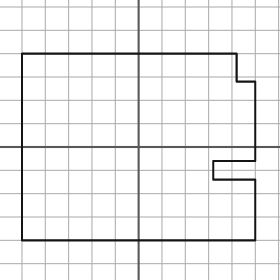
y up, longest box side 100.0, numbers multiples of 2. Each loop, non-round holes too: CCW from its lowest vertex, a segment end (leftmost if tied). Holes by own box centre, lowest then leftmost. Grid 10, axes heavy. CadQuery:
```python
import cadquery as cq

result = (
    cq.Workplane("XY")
    .moveTo(-50.0, -40.0)
    .lineTo(50.0, -40.0)
    .lineTo(50.0, -14.0)
    .lineTo(32.0, -14.0)
    .lineTo(32.0, -6.0)
    .lineTo(50.0, -6.0)
    .lineTo(50.0, 28.0)
    .lineTo(42.0, 28.0)
    .lineTo(42.0, 40.0)
    .lineTo(-50.0, 40.0)
    .close()
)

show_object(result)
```